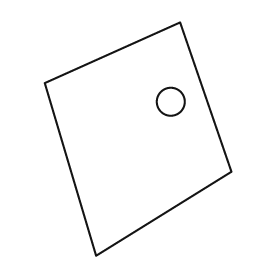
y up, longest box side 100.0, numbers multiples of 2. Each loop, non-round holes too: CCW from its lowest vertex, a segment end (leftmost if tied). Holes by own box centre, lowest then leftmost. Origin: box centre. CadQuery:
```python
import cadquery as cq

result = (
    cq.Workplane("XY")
    .moveTo(-18.0, -50.0)
    .lineTo(40.0, -14.0)
    .lineTo(18.0, 50.0)
    .lineTo(-40.0, 24.0)
    .close()
    .moveTo(14.0, 16.0)
    .circle(6.0)
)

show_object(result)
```